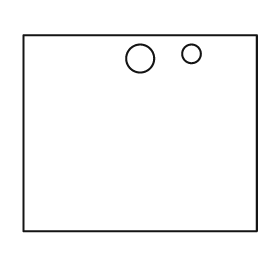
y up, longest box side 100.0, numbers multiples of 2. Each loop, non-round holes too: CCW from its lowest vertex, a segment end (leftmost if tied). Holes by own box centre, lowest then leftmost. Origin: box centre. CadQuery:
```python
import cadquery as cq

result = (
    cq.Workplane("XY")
    .moveTo(-50.0, -42.0)
    .lineTo(50.0, -42.0)
    .lineTo(50.0, 42.0)
    .lineTo(-50.0, 42.0)
    .close()
    .moveTo(0.0, 32.0)
    .circle(6.0)
    .moveTo(22.0, 34.0)
    .circle(4.0)
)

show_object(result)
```